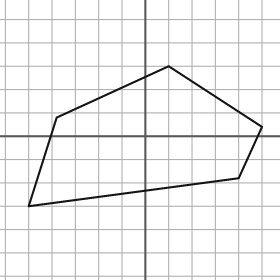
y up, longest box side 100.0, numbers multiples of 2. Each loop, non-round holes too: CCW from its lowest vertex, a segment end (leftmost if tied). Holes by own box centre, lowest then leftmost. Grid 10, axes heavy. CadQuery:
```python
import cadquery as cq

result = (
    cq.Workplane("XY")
    .moveTo(-50.0, -30.0)
    .lineTo(40.0, -18.0)
    .lineTo(50.0, 4.0)
    .lineTo(10.0, 30.0)
    .lineTo(-38.0, 8.0)
    .close()
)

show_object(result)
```